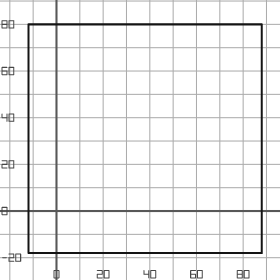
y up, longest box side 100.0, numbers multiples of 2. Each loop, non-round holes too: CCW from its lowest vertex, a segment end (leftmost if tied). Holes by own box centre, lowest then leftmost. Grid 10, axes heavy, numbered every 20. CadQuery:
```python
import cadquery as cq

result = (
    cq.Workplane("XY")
    .moveTo(-12.0, -18.0)
    .lineTo(88.0, -18.0)
    .lineTo(88.0, 80.0)
    .lineTo(-12.0, 80.0)
    .close()
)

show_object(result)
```